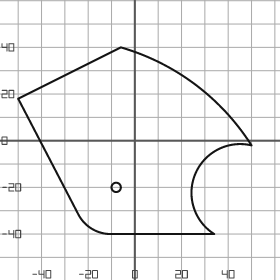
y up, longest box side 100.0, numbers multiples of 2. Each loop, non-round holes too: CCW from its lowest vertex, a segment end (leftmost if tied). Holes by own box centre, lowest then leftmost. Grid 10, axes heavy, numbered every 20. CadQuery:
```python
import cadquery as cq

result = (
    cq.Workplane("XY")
    .moveTo(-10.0, -40.0)
    .lineTo(34.0, -40.0)
    .threePointArc((26.0, -14.0), (50.0, -2.0))
    .threePointArc((26.0, 24.0), (-6.0, 40.0))
    .lineTo(-50.0, 18.0)
    .lineTo(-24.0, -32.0)
    .threePointArc((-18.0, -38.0), (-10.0, -40.0))
    .close()
    .moveTo(-8.0, -20.0)
    .circle(2.0)
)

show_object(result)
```